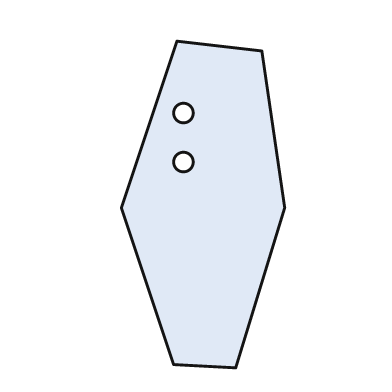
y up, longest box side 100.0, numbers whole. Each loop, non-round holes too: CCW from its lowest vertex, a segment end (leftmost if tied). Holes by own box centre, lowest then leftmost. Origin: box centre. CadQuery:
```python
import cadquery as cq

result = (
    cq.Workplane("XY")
    .moveTo(10.0, -50.0)
    .lineTo(25.0, -1.0)
    .lineTo(18.0, 47.0)
    .lineTo(-8.0, 50.0)
    .lineTo(-25.0, -1.0)
    .lineTo(-9.0, -49.0)
    .close()
    .moveTo(-6.0, 13.0)
    .circle(3.0)
    .moveTo(-6.0, 28.0)
    .circle(3.0)
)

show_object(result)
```